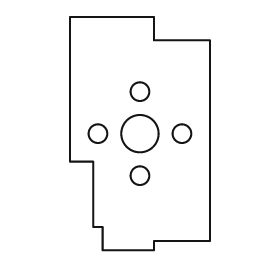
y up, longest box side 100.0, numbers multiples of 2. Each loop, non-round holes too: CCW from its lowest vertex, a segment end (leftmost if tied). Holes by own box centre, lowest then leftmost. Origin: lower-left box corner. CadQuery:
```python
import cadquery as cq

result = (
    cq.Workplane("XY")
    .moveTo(14.0, 0.0)
    .lineTo(36.0, 0.0)
    .lineTo(36.0, 4.0)
    .lineTo(60.0, 4.0)
    .lineTo(60.0, 90.0)
    .lineTo(36.0, 90.0)
    .lineTo(36.0, 100.0)
    .lineTo(0.0, 100.0)
    .lineTo(0.0, 38.0)
    .lineTo(10.0, 38.0)
    .lineTo(10.0, 10.0)
    .lineTo(14.0, 10.0)
    .close()
    .moveTo(30.0, 32.0)
    .circle(4.0)
    .moveTo(12.0, 50.0)
    .circle(4.0)
    .moveTo(30.0, 50.0)
    .circle(8.0)
    .moveTo(48.0, 50.0)
    .circle(4.0)
    .moveTo(30.0, 68.0)
    .circle(4.0)
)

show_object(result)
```